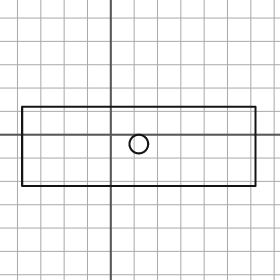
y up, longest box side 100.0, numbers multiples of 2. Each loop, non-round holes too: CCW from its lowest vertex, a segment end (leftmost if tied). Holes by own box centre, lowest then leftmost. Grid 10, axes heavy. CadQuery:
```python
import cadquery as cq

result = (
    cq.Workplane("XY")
    .moveTo(-38.0, -22.0)
    .lineTo(62.0, -22.0)
    .lineTo(62.0, 12.0)
    .lineTo(-38.0, 12.0)
    .close()
    .moveTo(12.0, -4.0)
    .circle(4.0)
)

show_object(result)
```